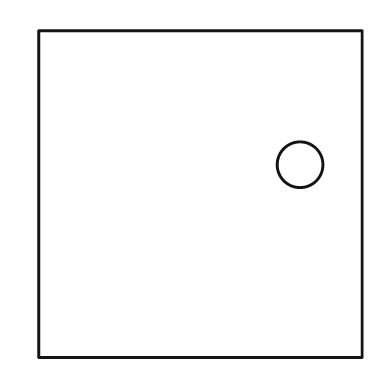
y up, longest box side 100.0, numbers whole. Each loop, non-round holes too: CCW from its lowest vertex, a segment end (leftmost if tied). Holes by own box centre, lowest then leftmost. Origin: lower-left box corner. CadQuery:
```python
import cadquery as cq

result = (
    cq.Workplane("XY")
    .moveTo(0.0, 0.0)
    .lineTo(99.0, 0.0)
    .lineTo(99.0, 100.0)
    .lineTo(0.0, 100.0)
    .close()
    .moveTo(80.0, 59.0)
    .circle(7.0)
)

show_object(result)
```